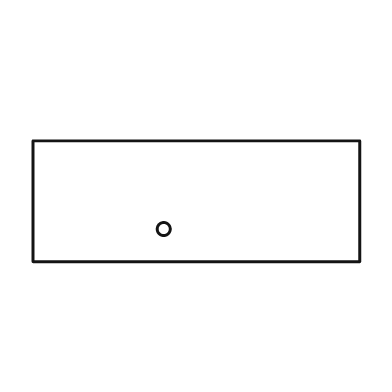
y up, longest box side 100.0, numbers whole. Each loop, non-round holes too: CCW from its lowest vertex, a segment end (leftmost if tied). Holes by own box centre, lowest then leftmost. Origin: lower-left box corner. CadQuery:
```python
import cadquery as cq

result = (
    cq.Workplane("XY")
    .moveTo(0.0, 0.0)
    .lineTo(100.0, 0.0)
    .lineTo(100.0, 37.0)
    .lineTo(0.0, 37.0)
    .close()
    .moveTo(40.0, 10.0)
    .circle(2.0)
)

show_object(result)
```